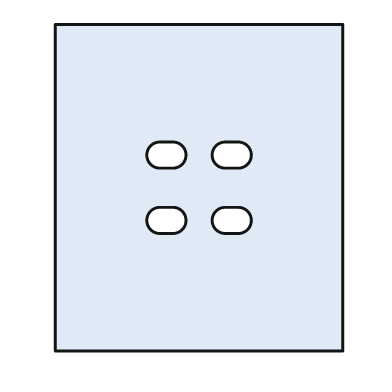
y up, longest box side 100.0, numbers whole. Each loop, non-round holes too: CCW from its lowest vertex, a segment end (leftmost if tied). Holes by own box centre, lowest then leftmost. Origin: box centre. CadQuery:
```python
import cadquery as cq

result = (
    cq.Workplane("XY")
    .moveTo(-44.0, -50.0)
    .lineTo(44.0, -50.0)
    .lineTo(44.0, 50.0)
    .lineTo(-44.0, 50.0)
    .close()
    .moveTo(-12.0, -14.0)
    .lineTo(-8.0, -14.0)
    .threePointArc((-4.0, -10.0), (-8.0, -6.0))
    .lineTo(-12.0, -6.0)
    .threePointArc((-16.0, -10.0), (-12.0, -14.0))
    .close()
    .moveTo(8.0, -14.0)
    .lineTo(12.0, -14.0)
    .threePointArc((16.0, -10.0), (12.0, -6.0))
    .lineTo(8.0, -6.0)
    .threePointArc((4.0, -10.0), (8.0, -14.0))
    .close()
    .moveTo(-12.0, 6.0)
    .lineTo(-8.0, 6.0)
    .threePointArc((-4.0, 10.0), (-8.0, 14.0))
    .lineTo(-12.0, 14.0)
    .threePointArc((-16.0, 10.0), (-12.0, 6.0))
    .close()
    .moveTo(8.0, 6.0)
    .lineTo(12.0, 6.0)
    .threePointArc((16.0, 10.0), (12.0, 14.0))
    .lineTo(8.0, 14.0)
    .threePointArc((4.0, 10.0), (8.0, 6.0))
    .close()
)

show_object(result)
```